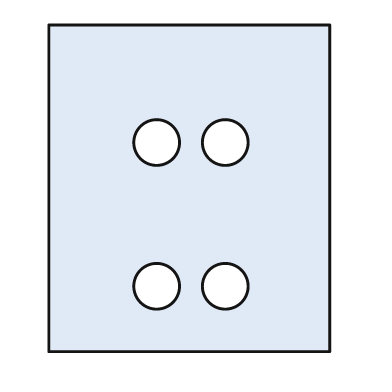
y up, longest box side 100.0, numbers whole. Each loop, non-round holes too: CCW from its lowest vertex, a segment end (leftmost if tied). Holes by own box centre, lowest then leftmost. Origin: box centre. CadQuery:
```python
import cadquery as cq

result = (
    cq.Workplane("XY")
    .moveTo(-43.0, -50.0)
    .lineTo(43.0, -50.0)
    .lineTo(43.0, 50.0)
    .lineTo(-43.0, 50.0)
    .close()
    .moveTo(-10.0, -30.0)
    .circle(7.0)
    .moveTo(11.0, -30.0)
    .circle(7.0)
    .moveTo(-10.0, 14.0)
    .circle(7.0)
    .moveTo(11.0, 14.0)
    .circle(7.0)
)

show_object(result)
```